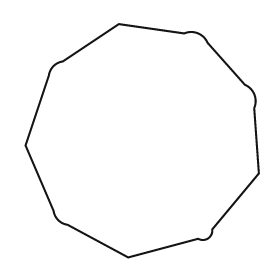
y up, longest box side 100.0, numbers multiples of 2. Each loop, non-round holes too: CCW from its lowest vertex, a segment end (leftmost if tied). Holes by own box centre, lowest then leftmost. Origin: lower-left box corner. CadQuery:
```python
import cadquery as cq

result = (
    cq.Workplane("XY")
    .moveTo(44.0, 0.0)
    .lineTo(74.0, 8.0)
    .threePointArc((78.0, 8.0), (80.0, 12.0))
    .lineTo(100.0, 36.0)
    .lineTo(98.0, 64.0)
    .threePointArc((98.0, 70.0), (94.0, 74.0))
    .lineTo(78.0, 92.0)
    .threePointArc((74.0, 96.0), (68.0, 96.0))
    .lineTo(40.0, 100.0)
    .lineTo(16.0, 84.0)
    .threePointArc((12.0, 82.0), (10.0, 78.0))
    .lineTo(0.0, 48.0)
    .lineTo(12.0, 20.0)
    .threePointArc((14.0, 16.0), (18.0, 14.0))
    .close()
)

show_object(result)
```